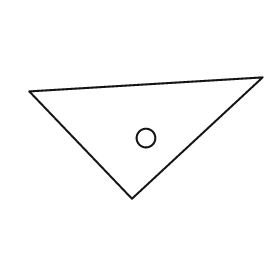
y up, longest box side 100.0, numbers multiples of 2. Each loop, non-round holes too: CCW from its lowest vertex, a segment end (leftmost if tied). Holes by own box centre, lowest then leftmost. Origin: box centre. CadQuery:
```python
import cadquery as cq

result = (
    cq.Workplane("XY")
    .moveTo(-6.0, -26.0)
    .lineTo(50.0, 26.0)
    .lineTo(-50.0, 20.0)
    .close()
    .moveTo(0.0, 0.0)
    .circle(4.0)
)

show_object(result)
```